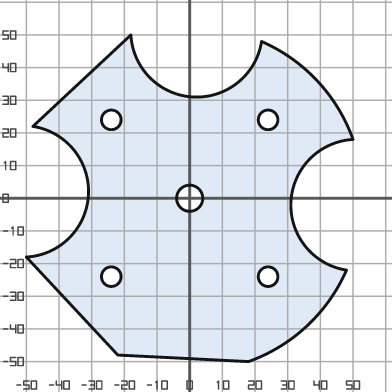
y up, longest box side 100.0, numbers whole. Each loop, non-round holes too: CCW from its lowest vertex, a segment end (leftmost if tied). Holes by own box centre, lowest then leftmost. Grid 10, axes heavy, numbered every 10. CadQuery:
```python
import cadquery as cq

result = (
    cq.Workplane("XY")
    .moveTo(18.0, -50.0)
    .threePointArc((36.0, -39.0), (48.0, -22.0))
    .threePointArc((31.0, -1.0), (50.0, 18.0))
    .threePointArc((39.0, 36.0), (22.0, 48.0))
    .threePointArc((1.0, 31.0), (-18.0, 50.0))
    .lineTo(-48.0, 22.0)
    .threePointArc((-31.0, 1.0), (-50.0, -18.0))
    .lineTo(-22.0, -48.0)
    .close()
    .moveTo(-24.0, -24.0)
    .circle(3.0)
    .moveTo(24.0, -24.0)
    .circle(3.0)
    .moveTo(0.0, 0.0)
    .circle(4.0)
    .moveTo(-24.0, 24.0)
    .circle(3.0)
    .moveTo(24.0, 24.0)
    .circle(3.0)
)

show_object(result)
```